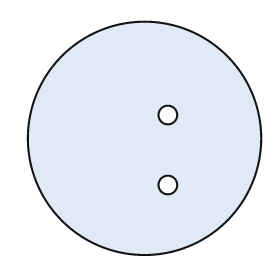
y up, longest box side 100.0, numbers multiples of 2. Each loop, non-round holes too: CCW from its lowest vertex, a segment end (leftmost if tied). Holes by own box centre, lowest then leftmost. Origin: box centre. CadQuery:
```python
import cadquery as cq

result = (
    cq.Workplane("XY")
    .moveTo(0.0, 0.0)
    .circle(50.0)
    .moveTo(10.0, -20.0)
    .circle(4.0)
    .moveTo(10.0, 10.0)
    .circle(4.0)
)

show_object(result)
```